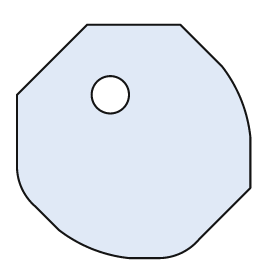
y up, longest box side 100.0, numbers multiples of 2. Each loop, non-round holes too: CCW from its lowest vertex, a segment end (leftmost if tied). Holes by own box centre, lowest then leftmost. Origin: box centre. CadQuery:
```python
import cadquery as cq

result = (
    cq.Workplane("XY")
    .moveTo(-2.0, -50.0)
    .lineTo(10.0, -50.0)
    .threePointArc((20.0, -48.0), (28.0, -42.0))
    .lineTo(50.0, -20.0)
    .lineTo(50.0, 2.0)
    .threePointArc((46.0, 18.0), (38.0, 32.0))
    .lineTo(20.0, 50.0)
    .lineTo(-20.0, 50.0)
    .lineTo(-50.0, 20.0)
    .lineTo(-50.0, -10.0)
    .threePointArc((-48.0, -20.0), (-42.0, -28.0))
    .lineTo(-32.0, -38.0)
    .threePointArc((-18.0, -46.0), (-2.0, -50.0))
    .close()
    .moveTo(-10.0, 20.0)
    .circle(8.0)
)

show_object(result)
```